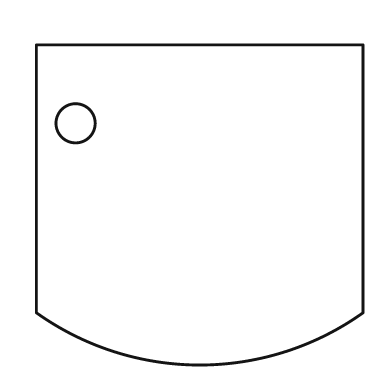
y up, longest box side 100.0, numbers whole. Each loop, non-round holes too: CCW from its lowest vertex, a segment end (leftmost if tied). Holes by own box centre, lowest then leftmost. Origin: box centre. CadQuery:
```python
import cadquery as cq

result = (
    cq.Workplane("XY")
    .moveTo(-50.0, -33.0)
    .threePointArc((0.0, -49.0), (50.0, -33.0))
    .lineTo(50.0, 49.0)
    .lineTo(-50.0, 49.0)
    .close()
    .moveTo(-38.0, 25.0)
    .circle(6.0)
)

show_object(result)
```